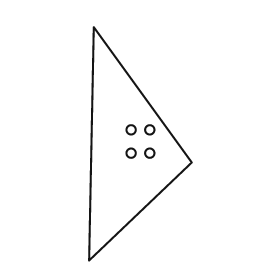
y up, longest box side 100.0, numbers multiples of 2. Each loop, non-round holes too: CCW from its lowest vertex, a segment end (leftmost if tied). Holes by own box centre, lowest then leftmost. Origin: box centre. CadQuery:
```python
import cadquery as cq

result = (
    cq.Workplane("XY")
    .moveTo(-22.0, -50.0)
    .lineTo(22.0, -8.0)
    .lineTo(-20.0, 50.0)
    .close()
    .moveTo(-4.0, -4.0)
    .circle(2.0)
    .moveTo(4.0, -4.0)
    .circle(2.0)
    .moveTo(-4.0, 6.0)
    .circle(2.0)
    .moveTo(4.0, 6.0)
    .circle(2.0)
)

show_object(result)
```